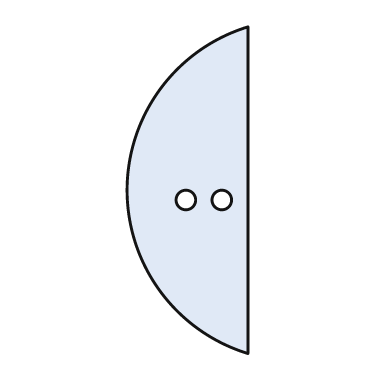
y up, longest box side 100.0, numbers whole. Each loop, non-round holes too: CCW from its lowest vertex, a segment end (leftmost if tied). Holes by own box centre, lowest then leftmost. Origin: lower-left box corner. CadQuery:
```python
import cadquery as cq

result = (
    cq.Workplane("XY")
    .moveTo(37.0, 0.0)
    .lineTo(37.0, 100.0)
    .threePointArc((0.0, 50.0), (37.0, 0.0))
    .close()
    .moveTo(18.0, 47.0)
    .circle(3.0)
    .moveTo(29.0, 47.0)
    .circle(3.0)
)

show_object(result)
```